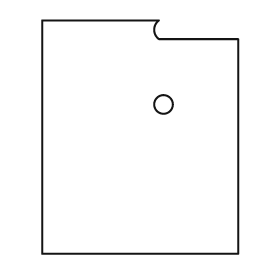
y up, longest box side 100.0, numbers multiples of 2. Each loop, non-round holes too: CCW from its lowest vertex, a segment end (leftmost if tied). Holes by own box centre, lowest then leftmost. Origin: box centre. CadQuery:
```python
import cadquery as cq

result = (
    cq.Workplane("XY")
    .moveTo(-42.0, -50.0)
    .lineTo(42.0, -50.0)
    .lineTo(42.0, 42.0)
    .lineTo(8.0, 42.0)
    .threePointArc((6.0, 46.0), (8.0, 50.0))
    .lineTo(-42.0, 50.0)
    .close()
    .moveTo(10.0, 14.0)
    .circle(4.0)
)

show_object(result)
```